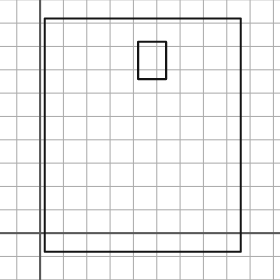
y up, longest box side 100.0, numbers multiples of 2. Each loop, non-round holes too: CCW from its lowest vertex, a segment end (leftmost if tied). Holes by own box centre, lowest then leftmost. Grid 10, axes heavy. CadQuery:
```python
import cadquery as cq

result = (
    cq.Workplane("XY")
    .moveTo(2.0, -8.0)
    .lineTo(86.0, -8.0)
    .lineTo(86.0, 92.0)
    .lineTo(2.0, 92.0)
    .close()
    .moveTo(42.0, 66.0)
    .lineTo(54.0, 66.0)
    .lineTo(54.0, 82.0)
    .lineTo(42.0, 82.0)
    .close()
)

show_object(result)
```